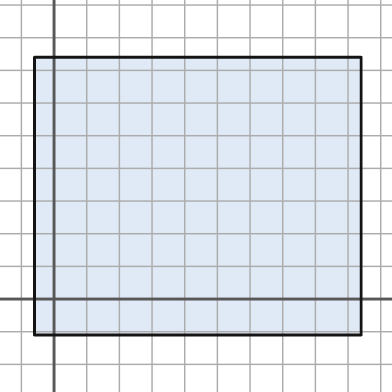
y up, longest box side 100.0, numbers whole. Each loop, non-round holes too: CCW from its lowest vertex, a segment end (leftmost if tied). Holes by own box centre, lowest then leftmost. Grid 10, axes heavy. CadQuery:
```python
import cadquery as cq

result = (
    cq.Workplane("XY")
    .moveTo(-6.0, -11.0)
    .lineTo(94.0, -11.0)
    .lineTo(94.0, 74.0)
    .lineTo(-6.0, 74.0)
    .close()
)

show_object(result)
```